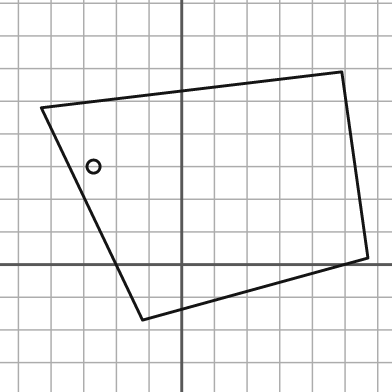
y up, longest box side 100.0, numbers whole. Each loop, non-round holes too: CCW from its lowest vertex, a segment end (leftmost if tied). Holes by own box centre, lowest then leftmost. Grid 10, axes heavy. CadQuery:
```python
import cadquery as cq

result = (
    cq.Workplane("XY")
    .moveTo(-12.0, -17.0)
    .lineTo(57.0, 2.0)
    .lineTo(49.0, 59.0)
    .lineTo(-43.0, 48.0)
    .close()
    .moveTo(-27.0, 30.0)
    .circle(2.0)
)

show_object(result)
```